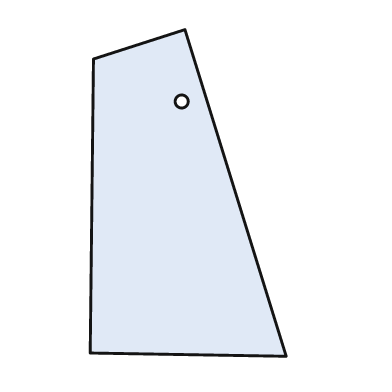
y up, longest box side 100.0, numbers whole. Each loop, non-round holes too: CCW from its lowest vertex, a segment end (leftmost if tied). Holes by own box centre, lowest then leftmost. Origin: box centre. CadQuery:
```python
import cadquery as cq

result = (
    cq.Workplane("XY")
    .moveTo(30.0, -50.0)
    .lineTo(-1.0, 50.0)
    .lineTo(-29.0, 41.0)
    .lineTo(-30.0, -49.0)
    .close()
    .moveTo(-2.0, 28.0)
    .circle(2.0)
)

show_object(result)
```